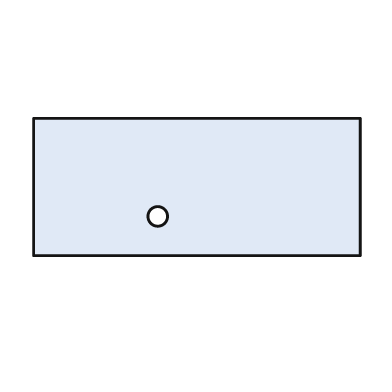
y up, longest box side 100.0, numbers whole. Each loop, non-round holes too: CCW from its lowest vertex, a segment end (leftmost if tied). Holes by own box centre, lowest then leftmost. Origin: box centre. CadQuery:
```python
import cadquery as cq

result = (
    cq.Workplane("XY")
    .moveTo(-50.0, -21.0)
    .lineTo(50.0, -21.0)
    .lineTo(50.0, 21.0)
    .lineTo(-50.0, 21.0)
    .close()
    .moveTo(-12.0, -9.0)
    .circle(3.0)
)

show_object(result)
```